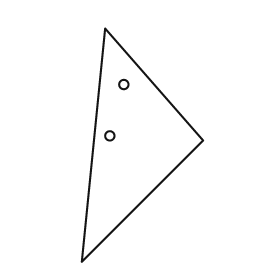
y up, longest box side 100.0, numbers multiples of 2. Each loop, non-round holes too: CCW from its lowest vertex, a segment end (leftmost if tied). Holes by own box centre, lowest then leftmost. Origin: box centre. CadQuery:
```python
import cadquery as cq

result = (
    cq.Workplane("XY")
    .moveTo(-26.0, -50.0)
    .lineTo(26.0, 2.0)
    .lineTo(-16.0, 50.0)
    .close()
    .moveTo(-14.0, 4.0)
    .circle(2.0)
    .moveTo(-8.0, 26.0)
    .circle(2.0)
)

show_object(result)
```